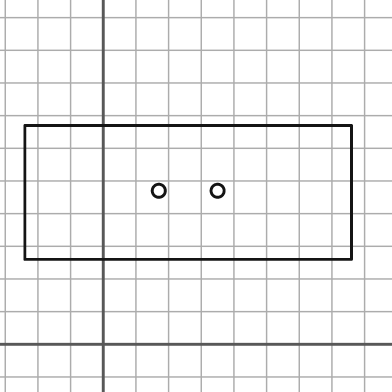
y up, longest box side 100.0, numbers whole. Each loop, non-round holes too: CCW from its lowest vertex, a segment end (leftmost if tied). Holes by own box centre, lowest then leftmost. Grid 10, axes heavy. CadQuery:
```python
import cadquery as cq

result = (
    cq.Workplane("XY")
    .moveTo(-24.0, 26.0)
    .lineTo(76.0, 26.0)
    .lineTo(76.0, 67.0)
    .lineTo(-24.0, 67.0)
    .close()
    .moveTo(17.0, 47.0)
    .circle(2.0)
    .moveTo(35.0, 47.0)
    .circle(2.0)
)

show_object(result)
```